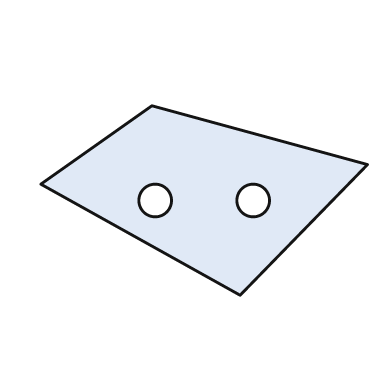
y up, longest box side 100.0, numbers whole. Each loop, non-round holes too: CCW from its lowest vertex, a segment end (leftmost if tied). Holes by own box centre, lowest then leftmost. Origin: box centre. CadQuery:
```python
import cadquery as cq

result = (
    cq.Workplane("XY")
    .moveTo(11.0, -29.0)
    .lineTo(50.0, 11.0)
    .lineTo(-16.0, 29.0)
    .lineTo(-50.0, 5.0)
    .close()
    .moveTo(-15.0, 0.0)
    .circle(5.0)
    .moveTo(15.0, 0.0)
    .circle(5.0)
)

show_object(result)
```